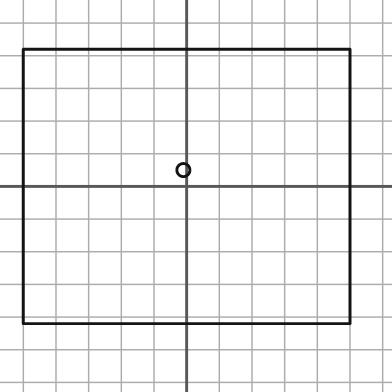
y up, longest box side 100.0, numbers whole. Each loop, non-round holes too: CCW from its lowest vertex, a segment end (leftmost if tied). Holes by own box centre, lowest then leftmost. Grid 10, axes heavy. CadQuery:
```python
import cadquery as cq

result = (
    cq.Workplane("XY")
    .moveTo(-50.0, -42.0)
    .lineTo(50.0, -42.0)
    .lineTo(50.0, 42.0)
    .lineTo(-50.0, 42.0)
    .close()
    .moveTo(-1.0, 5.0)
    .circle(2.0)
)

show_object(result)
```